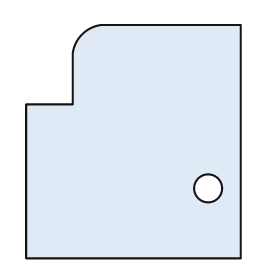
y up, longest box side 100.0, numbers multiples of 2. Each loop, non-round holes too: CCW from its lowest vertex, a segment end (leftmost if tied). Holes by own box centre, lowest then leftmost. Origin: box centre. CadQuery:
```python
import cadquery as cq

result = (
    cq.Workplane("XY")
    .moveTo(-46.0, -50.0)
    .lineTo(46.0, -50.0)
    .lineTo(46.0, 50.0)
    .lineTo(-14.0, 50.0)
    .threePointArc((-22.0, 46.0), (-26.0, 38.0))
    .lineTo(-26.0, 16.0)
    .lineTo(-46.0, 16.0)
    .close()
    .moveTo(32.0, -20.0)
    .circle(6.0)
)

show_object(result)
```